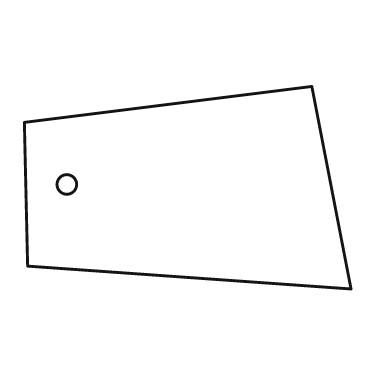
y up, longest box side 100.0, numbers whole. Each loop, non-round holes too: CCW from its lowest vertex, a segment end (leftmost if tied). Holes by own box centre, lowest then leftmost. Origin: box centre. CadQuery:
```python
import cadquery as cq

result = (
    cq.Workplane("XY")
    .moveTo(50.0, -31.0)
    .lineTo(38.0, 31.0)
    .lineTo(-50.0, 20.0)
    .lineTo(-49.0, -24.0)
    .close()
    .moveTo(-37.0, 1.0)
    .circle(3.0)
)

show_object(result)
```